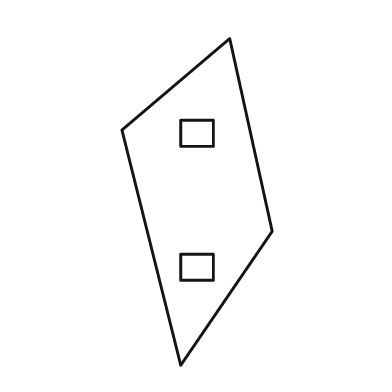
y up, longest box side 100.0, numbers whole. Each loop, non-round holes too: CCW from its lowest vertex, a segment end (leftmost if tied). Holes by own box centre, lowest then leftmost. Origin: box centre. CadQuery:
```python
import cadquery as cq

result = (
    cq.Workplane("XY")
    .moveTo(-5.0, -50.0)
    .lineTo(23.0, -9.0)
    .lineTo(10.0, 50.0)
    .lineTo(-23.0, 22.0)
    .close()
    .moveTo(-5.0, -24.0)
    .lineTo(5.0, -24.0)
    .lineTo(5.0, -16.0)
    .lineTo(-5.0, -16.0)
    .close()
    .moveTo(-5.0, 17.0)
    .lineTo(5.0, 17.0)
    .lineTo(5.0, 25.0)
    .lineTo(-5.0, 25.0)
    .close()
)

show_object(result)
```